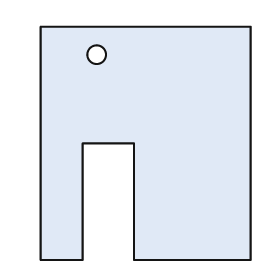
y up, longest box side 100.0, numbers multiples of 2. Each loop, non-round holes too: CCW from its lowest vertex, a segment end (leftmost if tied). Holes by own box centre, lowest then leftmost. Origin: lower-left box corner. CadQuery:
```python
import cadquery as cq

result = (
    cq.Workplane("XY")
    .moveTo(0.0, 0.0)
    .lineTo(18.0, 0.0)
    .lineTo(18.0, 50.0)
    .lineTo(40.0, 50.0)
    .lineTo(40.0, 0.0)
    .lineTo(90.0, 0.0)
    .lineTo(90.0, 100.0)
    .lineTo(0.0, 100.0)
    .close()
    .moveTo(24.0, 88.0)
    .circle(4.0)
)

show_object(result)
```